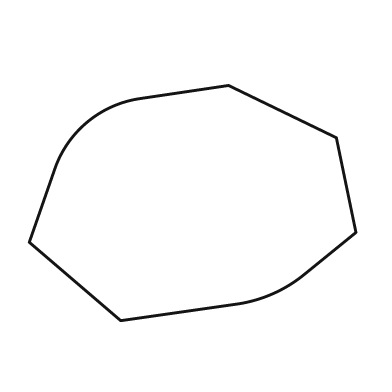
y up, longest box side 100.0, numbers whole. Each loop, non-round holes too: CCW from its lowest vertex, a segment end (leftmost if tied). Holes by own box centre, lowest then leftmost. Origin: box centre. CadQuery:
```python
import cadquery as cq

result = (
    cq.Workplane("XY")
    .moveTo(-22.0, -36.0)
    .lineTo(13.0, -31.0)
    .threePointArc((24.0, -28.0), (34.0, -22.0))
    .lineTo(50.0, -9.0)
    .lineTo(44.0, 20.0)
    .lineTo(11.0, 36.0)
    .lineTo(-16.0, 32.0)
    .threePointArc((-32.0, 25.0), (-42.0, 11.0))
    .lineTo(-50.0, -12.0)
    .close()
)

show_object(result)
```